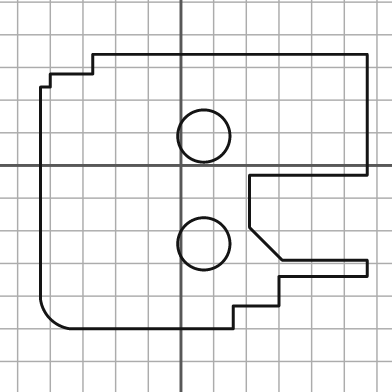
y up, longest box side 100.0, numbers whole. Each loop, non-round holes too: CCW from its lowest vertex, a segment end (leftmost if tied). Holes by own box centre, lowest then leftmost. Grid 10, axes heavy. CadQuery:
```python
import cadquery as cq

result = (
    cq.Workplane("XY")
    .moveTo(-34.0, -50.0)
    .lineTo(16.0, -50.0)
    .lineTo(16.0, -43.0)
    .lineTo(30.0, -43.0)
    .lineTo(30.0, -34.0)
    .lineTo(57.0, -34.0)
    .lineTo(57.0, -29.0)
    .lineTo(31.0, -29.0)
    .lineTo(21.0, -19.0)
    .lineTo(21.0, -3.0)
    .lineTo(57.0, -3.0)
    .lineTo(57.0, 34.0)
    .lineTo(-27.0, 34.0)
    .lineTo(-27.0, 28.0)
    .lineTo(-40.0, 28.0)
    .lineTo(-40.0, 24.0)
    .lineTo(-43.0, 24.0)
    .lineTo(-43.0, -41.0)
    .threePointArc((-40.0, -47.0), (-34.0, -50.0))
    .close()
    .moveTo(7.0, -24.0)
    .circle(8.0)
    .moveTo(7.0, 9.0)
    .circle(8.0)
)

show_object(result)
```